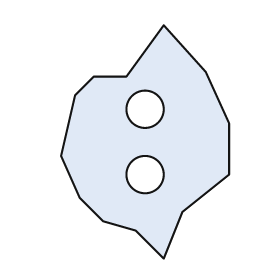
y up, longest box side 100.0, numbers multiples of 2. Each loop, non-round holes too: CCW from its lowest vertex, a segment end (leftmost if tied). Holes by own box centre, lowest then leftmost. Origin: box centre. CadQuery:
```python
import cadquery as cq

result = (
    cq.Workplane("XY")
    .moveTo(8.0, -50.0)
    .lineTo(16.0, -30.0)
    .lineTo(36.0, -14.0)
    .lineTo(36.0, 8.0)
    .lineTo(26.0, 30.0)
    .lineTo(8.0, 50.0)
    .lineTo(-8.0, 28.0)
    .lineTo(-22.0, 28.0)
    .lineTo(-30.0, 20.0)
    .lineTo(-36.0, -6.0)
    .lineTo(-28.0, -24.0)
    .lineTo(-18.0, -34.0)
    .lineTo(-4.0, -38.0)
    .close()
    .moveTo(0.0, -14.0)
    .circle(8.0)
    .moveTo(0.0, 14.0)
    .circle(8.0)
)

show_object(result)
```